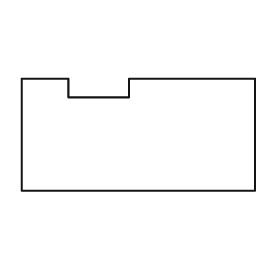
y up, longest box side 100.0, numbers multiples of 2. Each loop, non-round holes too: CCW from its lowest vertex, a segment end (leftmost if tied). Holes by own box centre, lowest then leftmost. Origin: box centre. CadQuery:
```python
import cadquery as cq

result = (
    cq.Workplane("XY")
    .moveTo(-50.0, -24.0)
    .lineTo(50.0, -24.0)
    .lineTo(50.0, 24.0)
    .lineTo(-4.0, 24.0)
    .lineTo(-4.0, 16.0)
    .lineTo(-30.0, 16.0)
    .lineTo(-30.0, 24.0)
    .lineTo(-50.0, 24.0)
    .close()
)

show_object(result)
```